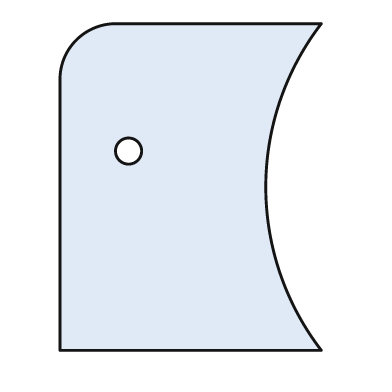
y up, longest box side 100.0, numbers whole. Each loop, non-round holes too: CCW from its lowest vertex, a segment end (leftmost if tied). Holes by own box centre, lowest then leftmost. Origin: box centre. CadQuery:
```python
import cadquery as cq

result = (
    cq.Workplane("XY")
    .moveTo(-40.0, -50.0)
    .lineTo(40.0, -50.0)
    .threePointArc((23.0, 0.0), (40.0, 50.0))
    .lineTo(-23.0, 50.0)
    .threePointArc((-35.0, 45.0), (-40.0, 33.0))
    .close()
    .moveTo(-19.0, 11.0)
    .circle(4.0)
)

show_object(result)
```